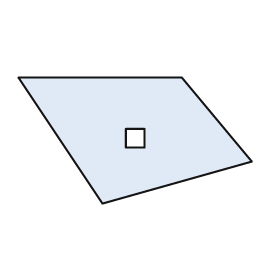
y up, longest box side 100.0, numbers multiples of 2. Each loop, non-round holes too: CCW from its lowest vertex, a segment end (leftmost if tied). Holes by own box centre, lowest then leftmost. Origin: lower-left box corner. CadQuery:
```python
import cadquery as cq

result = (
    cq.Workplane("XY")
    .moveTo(36.0, 0.0)
    .lineTo(100.0, 18.0)
    .lineTo(70.0, 54.0)
    .lineTo(0.0, 54.0)
    .close()
    .moveTo(46.0, 24.0)
    .lineTo(54.0, 24.0)
    .lineTo(54.0, 32.0)
    .lineTo(46.0, 32.0)
    .close()
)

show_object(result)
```